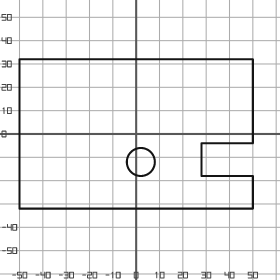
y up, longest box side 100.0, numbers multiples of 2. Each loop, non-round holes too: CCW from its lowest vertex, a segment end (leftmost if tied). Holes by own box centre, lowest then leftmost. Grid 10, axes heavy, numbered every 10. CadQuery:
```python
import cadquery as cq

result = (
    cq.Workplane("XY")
    .moveTo(-50.0, -32.0)
    .lineTo(50.0, -32.0)
    .lineTo(50.0, -18.0)
    .lineTo(28.0, -18.0)
    .lineTo(28.0, -4.0)
    .lineTo(50.0, -4.0)
    .lineTo(50.0, 32.0)
    .lineTo(-50.0, 32.0)
    .close()
    .moveTo(2.0, -12.0)
    .circle(6.0)
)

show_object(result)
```